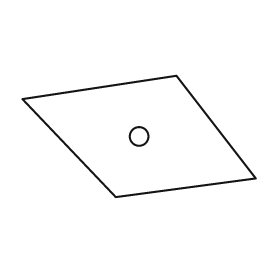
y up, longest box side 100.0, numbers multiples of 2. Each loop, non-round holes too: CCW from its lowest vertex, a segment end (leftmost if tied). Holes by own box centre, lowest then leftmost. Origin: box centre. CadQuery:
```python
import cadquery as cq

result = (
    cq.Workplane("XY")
    .moveTo(-10.0, -26.0)
    .lineTo(50.0, -18.0)
    .lineTo(16.0, 26.0)
    .lineTo(-50.0, 16.0)
    .close()
    .moveTo(0.0, 0.0)
    .circle(4.0)
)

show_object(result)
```